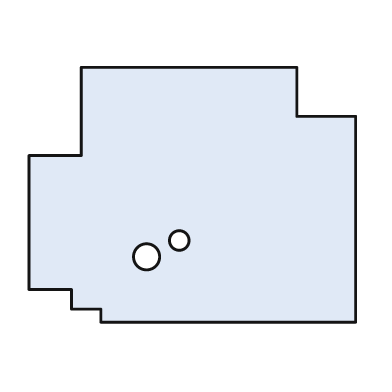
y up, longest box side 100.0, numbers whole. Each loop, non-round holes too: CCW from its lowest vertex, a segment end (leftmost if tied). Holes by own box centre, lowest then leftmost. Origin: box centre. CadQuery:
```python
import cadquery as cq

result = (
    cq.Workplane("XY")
    .moveTo(-28.0, -39.0)
    .lineTo(50.0, -39.0)
    .lineTo(50.0, 24.0)
    .lineTo(32.0, 24.0)
    .lineTo(32.0, 39.0)
    .lineTo(-34.0, 39.0)
    .lineTo(-34.0, 12.0)
    .lineTo(-50.0, 12.0)
    .lineTo(-50.0, -29.0)
    .lineTo(-37.0, -29.0)
    .lineTo(-37.0, -35.0)
    .lineTo(-28.0, -35.0)
    .close()
    .moveTo(-14.0, -19.0)
    .circle(4.0)
    .moveTo(-4.0, -14.0)
    .circle(3.0)
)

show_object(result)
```